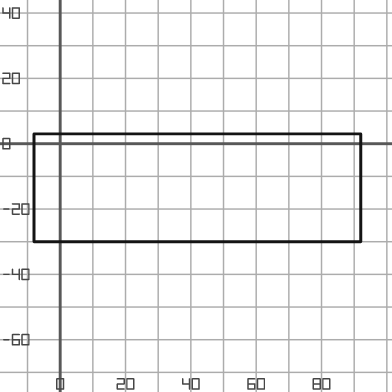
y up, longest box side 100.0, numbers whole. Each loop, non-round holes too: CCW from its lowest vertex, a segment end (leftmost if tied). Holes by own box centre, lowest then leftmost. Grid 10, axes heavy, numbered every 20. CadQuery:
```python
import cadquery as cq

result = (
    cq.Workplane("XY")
    .moveTo(-8.0, -30.0)
    .lineTo(92.0, -30.0)
    .lineTo(92.0, 3.0)
    .lineTo(-8.0, 3.0)
    .close()
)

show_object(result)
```